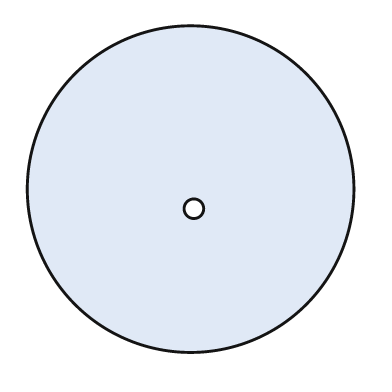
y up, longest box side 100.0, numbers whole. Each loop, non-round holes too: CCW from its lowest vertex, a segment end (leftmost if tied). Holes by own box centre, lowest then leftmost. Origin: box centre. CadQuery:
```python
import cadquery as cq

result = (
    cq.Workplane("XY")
    .moveTo(0.0, 0.0)
    .circle(50.0)
    .moveTo(1.0, -6.0)
    .circle(3.0)
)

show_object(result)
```